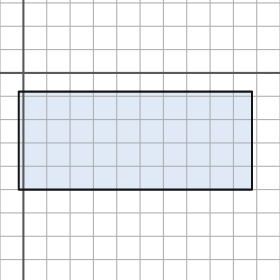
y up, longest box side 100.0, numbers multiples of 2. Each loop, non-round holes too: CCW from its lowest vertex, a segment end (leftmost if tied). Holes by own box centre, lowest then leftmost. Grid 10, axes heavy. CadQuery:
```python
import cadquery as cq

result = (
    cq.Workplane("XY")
    .moveTo(-2.0, -50.0)
    .lineTo(98.0, -50.0)
    .lineTo(98.0, -8.0)
    .lineTo(-2.0, -8.0)
    .close()
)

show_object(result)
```